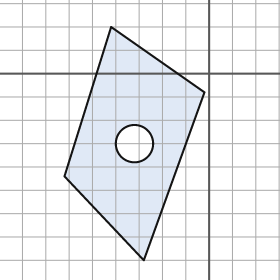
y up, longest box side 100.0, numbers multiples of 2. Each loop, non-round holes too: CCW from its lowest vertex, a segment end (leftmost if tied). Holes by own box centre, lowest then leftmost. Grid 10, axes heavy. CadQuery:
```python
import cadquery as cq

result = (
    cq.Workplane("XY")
    .moveTo(-28.0, -80.0)
    .lineTo(-2.0, -8.0)
    .lineTo(-42.0, 20.0)
    .lineTo(-62.0, -44.0)
    .close()
    .moveTo(-32.0, -30.0)
    .circle(8.0)
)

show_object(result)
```